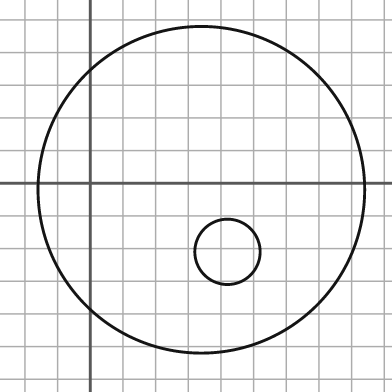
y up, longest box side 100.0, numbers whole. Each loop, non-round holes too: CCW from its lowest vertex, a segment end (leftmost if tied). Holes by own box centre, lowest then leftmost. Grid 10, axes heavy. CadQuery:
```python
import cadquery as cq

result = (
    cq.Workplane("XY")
    .moveTo(34.0, -2.0)
    .circle(50.0)
    .moveTo(42.0, -21.0)
    .circle(10.0)
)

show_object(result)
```